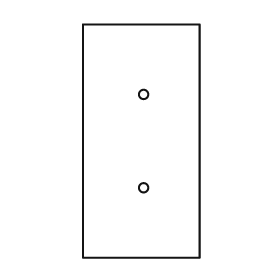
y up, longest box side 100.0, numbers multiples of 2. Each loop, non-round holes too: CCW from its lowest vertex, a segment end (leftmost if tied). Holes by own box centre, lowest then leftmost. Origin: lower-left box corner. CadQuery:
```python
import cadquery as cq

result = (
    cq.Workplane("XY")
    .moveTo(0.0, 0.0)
    .lineTo(50.0, 0.0)
    .lineTo(50.0, 100.0)
    .lineTo(0.0, 100.0)
    .close()
    .moveTo(26.0, 30.0)
    .circle(2.0)
    .moveTo(26.0, 70.0)
    .circle(2.0)
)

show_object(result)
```